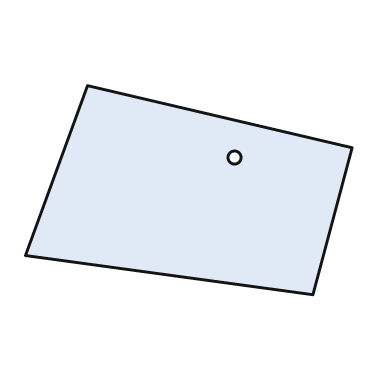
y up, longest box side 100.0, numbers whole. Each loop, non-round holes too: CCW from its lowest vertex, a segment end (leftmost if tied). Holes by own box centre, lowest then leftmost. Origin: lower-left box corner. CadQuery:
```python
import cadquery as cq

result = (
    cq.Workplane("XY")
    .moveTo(88.0, 0.0)
    .lineTo(100.0, 45.0)
    .lineTo(19.0, 64.0)
    .lineTo(0.0, 12.0)
    .close()
    .moveTo(64.0, 42.0)
    .circle(2.0)
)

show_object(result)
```